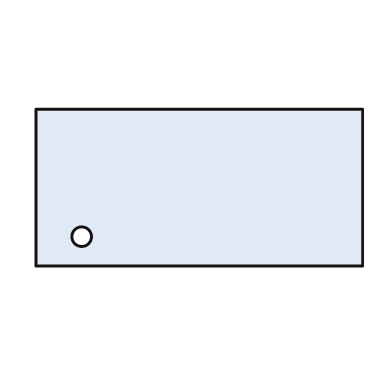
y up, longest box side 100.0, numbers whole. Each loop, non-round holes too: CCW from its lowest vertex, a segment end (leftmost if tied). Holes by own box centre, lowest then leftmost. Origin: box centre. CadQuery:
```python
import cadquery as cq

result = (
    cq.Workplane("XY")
    .moveTo(-50.0, -24.0)
    .lineTo(50.0, -24.0)
    .lineTo(50.0, 24.0)
    .lineTo(-50.0, 24.0)
    .close()
    .moveTo(-36.0, -15.0)
    .circle(3.0)
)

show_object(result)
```